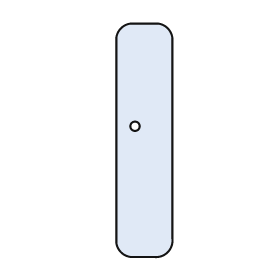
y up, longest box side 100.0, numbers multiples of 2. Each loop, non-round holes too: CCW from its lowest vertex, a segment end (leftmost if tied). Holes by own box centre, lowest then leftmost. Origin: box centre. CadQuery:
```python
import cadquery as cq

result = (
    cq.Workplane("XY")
    .moveTo(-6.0, -50.0)
    .lineTo(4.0, -50.0)
    .threePointArc((10.0, -48.0), (12.0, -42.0))
    .lineTo(12.0, 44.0)
    .threePointArc((10.0, 48.0), (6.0, 50.0))
    .lineTo(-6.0, 50.0)
    .threePointArc((-10.0, 48.0), (-12.0, 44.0))
    .lineTo(-12.0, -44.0)
    .threePointArc((-10.0, -48.0), (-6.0, -50.0))
    .close()
    .moveTo(-4.0, 6.0)
    .circle(2.0)
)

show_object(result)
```